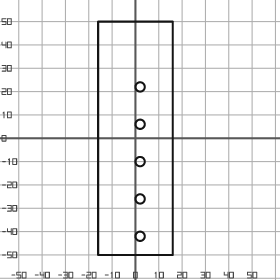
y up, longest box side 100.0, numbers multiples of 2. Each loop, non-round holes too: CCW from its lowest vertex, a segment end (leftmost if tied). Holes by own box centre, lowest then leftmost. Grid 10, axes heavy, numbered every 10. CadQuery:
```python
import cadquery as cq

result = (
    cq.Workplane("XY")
    .moveTo(-16.0, -50.0)
    .lineTo(16.0, -50.0)
    .lineTo(16.0, 50.0)
    .lineTo(-16.0, 50.0)
    .close()
    .moveTo(2.0, -42.0)
    .circle(2.0)
    .moveTo(2.0, -26.0)
    .circle(2.0)
    .moveTo(2.0, -10.0)
    .circle(2.0)
    .moveTo(2.0, 6.0)
    .circle(2.0)
    .moveTo(2.0, 22.0)
    .circle(2.0)
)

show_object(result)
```